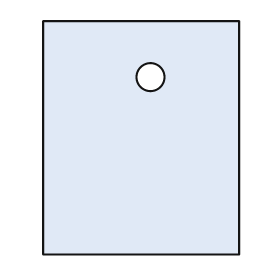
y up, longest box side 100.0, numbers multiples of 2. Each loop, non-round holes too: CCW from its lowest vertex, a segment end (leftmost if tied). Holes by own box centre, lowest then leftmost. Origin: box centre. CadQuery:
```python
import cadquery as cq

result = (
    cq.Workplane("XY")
    .moveTo(-42.0, -50.0)
    .lineTo(42.0, -50.0)
    .lineTo(42.0, 50.0)
    .lineTo(-42.0, 50.0)
    .close()
    .moveTo(4.0, 26.0)
    .circle(6.0)
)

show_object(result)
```